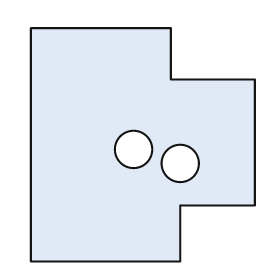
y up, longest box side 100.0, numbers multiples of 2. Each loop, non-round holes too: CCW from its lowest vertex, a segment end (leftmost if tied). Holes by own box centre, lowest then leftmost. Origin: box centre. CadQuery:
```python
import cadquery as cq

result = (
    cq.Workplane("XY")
    .moveTo(-48.0, -50.0)
    .lineTo(16.0, -50.0)
    .lineTo(16.0, -26.0)
    .lineTo(48.0, -26.0)
    .lineTo(48.0, 28.0)
    .lineTo(12.0, 28.0)
    .lineTo(12.0, 50.0)
    .lineTo(-48.0, 50.0)
    .close()
    .moveTo(16.0, -8.0)
    .circle(8.0)
    .moveTo(-4.0, -2.0)
    .circle(8.0)
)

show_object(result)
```